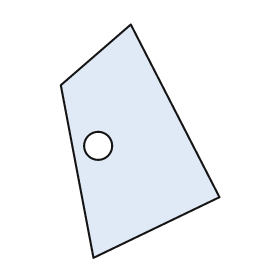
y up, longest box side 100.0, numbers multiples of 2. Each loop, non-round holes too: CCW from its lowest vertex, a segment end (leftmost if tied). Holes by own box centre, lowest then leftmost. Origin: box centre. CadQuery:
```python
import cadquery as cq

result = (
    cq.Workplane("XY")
    .moveTo(-20.0, -50.0)
    .lineTo(34.0, -24.0)
    .lineTo(-4.0, 50.0)
    .lineTo(-34.0, 24.0)
    .close()
    .moveTo(-18.0, -2.0)
    .circle(6.0)
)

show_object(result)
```